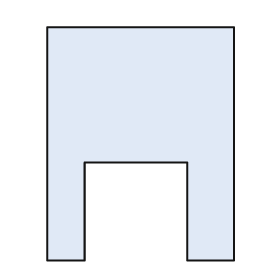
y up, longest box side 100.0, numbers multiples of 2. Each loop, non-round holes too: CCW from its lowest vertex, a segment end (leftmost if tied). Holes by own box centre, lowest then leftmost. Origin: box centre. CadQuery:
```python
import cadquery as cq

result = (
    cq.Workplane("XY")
    .moveTo(-40.0, -50.0)
    .lineTo(-24.0, -50.0)
    .lineTo(-24.0, -8.0)
    .lineTo(20.0, -8.0)
    .lineTo(20.0, -50.0)
    .lineTo(40.0, -50.0)
    .lineTo(40.0, 50.0)
    .lineTo(-40.0, 50.0)
    .close()
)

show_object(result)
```